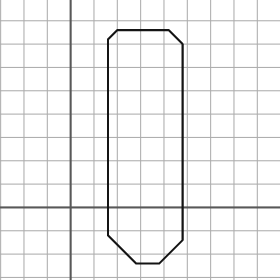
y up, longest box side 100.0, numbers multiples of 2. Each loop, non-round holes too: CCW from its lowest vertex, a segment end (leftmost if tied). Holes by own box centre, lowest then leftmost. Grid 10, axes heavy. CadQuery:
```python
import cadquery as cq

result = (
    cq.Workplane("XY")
    .moveTo(28.0, -24.0)
    .lineTo(38.0, -24.0)
    .lineTo(48.0, -14.0)
    .lineTo(48.0, 70.0)
    .lineTo(42.0, 76.0)
    .lineTo(20.0, 76.0)
    .lineTo(16.0, 72.0)
    .lineTo(16.0, -12.0)
    .close()
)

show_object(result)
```